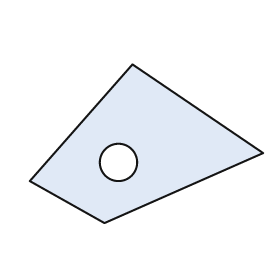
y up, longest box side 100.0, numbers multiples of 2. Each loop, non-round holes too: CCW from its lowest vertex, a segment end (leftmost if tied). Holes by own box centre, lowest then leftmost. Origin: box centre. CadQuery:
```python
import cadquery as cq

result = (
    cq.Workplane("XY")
    .moveTo(-18.0, -34.0)
    .lineTo(50.0, -4.0)
    .lineTo(-6.0, 34.0)
    .lineTo(-50.0, -16.0)
    .close()
    .moveTo(-12.0, -8.0)
    .circle(8.0)
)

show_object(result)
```